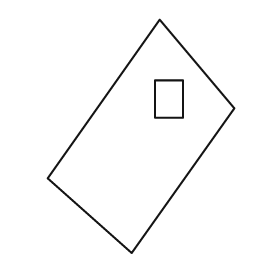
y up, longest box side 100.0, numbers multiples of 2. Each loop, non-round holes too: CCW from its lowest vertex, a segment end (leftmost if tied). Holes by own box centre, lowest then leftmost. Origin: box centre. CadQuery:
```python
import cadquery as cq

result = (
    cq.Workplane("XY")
    .moveTo(-4.0, -50.0)
    .lineTo(40.0, 12.0)
    .lineTo(8.0, 50.0)
    .lineTo(-40.0, -18.0)
    .close()
    .moveTo(6.0, 8.0)
    .lineTo(18.0, 8.0)
    .lineTo(18.0, 24.0)
    .lineTo(6.0, 24.0)
    .close()
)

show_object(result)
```